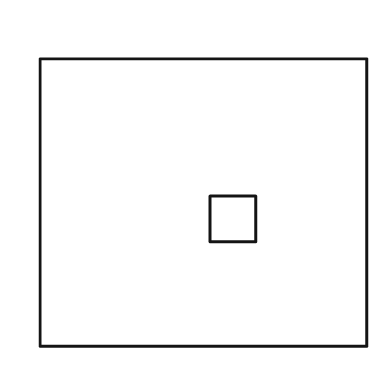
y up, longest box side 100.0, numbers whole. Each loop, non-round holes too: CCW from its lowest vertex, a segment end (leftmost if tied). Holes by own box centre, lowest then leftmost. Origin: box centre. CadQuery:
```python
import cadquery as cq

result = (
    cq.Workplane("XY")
    .moveTo(-50.0, -44.0)
    .lineTo(50.0, -44.0)
    .lineTo(50.0, 44.0)
    .lineTo(-50.0, 44.0)
    .close()
    .moveTo(2.0, -12.0)
    .lineTo(16.0, -12.0)
    .lineTo(16.0, 2.0)
    .lineTo(2.0, 2.0)
    .close()
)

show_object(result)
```